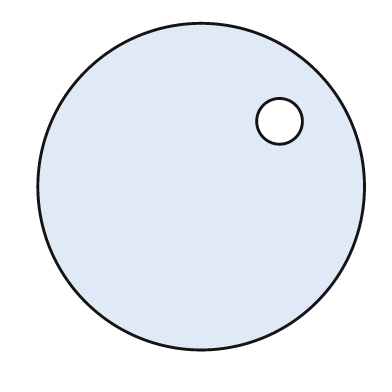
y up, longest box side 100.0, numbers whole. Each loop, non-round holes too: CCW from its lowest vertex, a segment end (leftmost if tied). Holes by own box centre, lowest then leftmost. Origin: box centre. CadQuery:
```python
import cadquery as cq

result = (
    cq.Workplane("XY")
    .moveTo(0.0, 0.0)
    .circle(50.0)
    .moveTo(24.0, 20.0)
    .circle(7.0)
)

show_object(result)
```